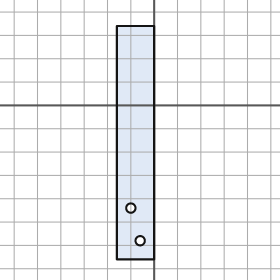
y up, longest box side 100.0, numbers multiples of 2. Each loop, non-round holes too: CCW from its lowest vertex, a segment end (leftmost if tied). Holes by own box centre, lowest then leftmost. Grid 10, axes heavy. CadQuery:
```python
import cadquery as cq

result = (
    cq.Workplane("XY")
    .moveTo(-16.0, -66.0)
    .lineTo(0.0, -66.0)
    .lineTo(0.0, 34.0)
    .lineTo(-16.0, 34.0)
    .close()
    .moveTo(-6.0, -58.0)
    .circle(2.0)
    .moveTo(-10.0, -44.0)
    .circle(2.0)
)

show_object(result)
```